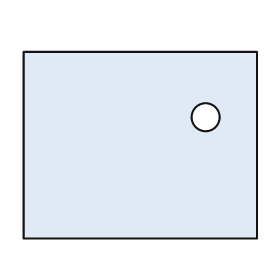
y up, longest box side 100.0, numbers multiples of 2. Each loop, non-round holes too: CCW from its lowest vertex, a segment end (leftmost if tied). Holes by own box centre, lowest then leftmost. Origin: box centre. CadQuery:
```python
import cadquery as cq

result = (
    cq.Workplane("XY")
    .moveTo(-50.0, -40.0)
    .lineTo(50.0, -40.0)
    .lineTo(50.0, 40.0)
    .lineTo(-50.0, 40.0)
    .close()
    .moveTo(28.0, 12.0)
    .circle(6.0)
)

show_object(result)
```